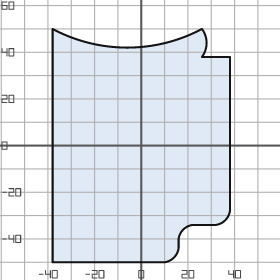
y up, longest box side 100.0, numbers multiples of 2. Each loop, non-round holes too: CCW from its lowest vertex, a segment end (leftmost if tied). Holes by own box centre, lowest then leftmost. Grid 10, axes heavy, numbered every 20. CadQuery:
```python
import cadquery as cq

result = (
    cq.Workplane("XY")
    .moveTo(-38.0, -50.0)
    .lineTo(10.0, -50.0)
    .threePointArc((14.0, -48.0), (16.0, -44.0))
    .lineTo(16.0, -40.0)
    .threePointArc((18.0, -36.0), (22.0, -34.0))
    .lineTo(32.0, -34.0)
    .threePointArc((36.0, -32.0), (38.0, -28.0))
    .lineTo(38.0, 38.0)
    .lineTo(26.0, 38.0)
    .threePointArc((28.0, 44.0), (26.0, 50.0))
    .threePointArc((-6.0, 42.0), (-38.0, 50.0))
    .close()
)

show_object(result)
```